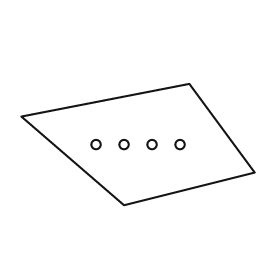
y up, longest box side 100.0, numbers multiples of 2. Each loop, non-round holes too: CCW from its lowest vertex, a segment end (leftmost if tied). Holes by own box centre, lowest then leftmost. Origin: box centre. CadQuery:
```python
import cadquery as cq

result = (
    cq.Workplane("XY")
    .moveTo(-6.0, -26.0)
    .lineTo(50.0, -12.0)
    .lineTo(22.0, 26.0)
    .lineTo(-50.0, 12.0)
    .close()
    .moveTo(-18.0, 0.0)
    .circle(2.0)
    .moveTo(-6.0, 0.0)
    .circle(2.0)
    .moveTo(6.0, 0.0)
    .circle(2.0)
    .moveTo(18.0, 0.0)
    .circle(2.0)
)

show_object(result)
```